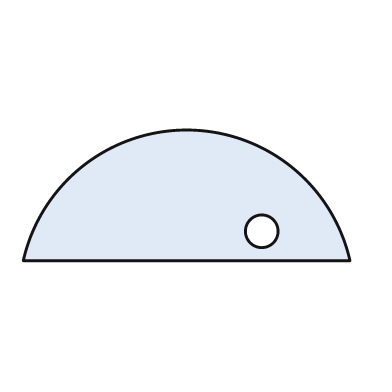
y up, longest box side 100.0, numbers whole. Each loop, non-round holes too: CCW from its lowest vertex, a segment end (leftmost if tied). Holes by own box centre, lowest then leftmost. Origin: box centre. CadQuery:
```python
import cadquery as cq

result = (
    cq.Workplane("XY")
    .moveTo(-50.0, -20.0)
    .lineTo(50.0, -20.0)
    .threePointArc((0.0, 20.0), (-50.0, -20.0))
    .close()
    .moveTo(23.0, -11.0)
    .circle(5.0)
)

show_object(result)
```